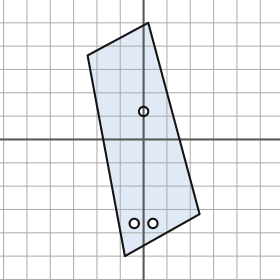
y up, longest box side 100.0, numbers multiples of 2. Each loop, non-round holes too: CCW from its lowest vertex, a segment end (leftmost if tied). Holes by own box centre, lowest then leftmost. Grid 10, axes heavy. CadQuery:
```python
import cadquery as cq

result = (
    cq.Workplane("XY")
    .moveTo(-8.0, -50.0)
    .lineTo(24.0, -32.0)
    .lineTo(2.0, 50.0)
    .lineTo(-24.0, 36.0)
    .close()
    .moveTo(-4.0, -36.0)
    .circle(2.0)
    .moveTo(4.0, -36.0)
    .circle(2.0)
    .moveTo(0.0, 12.0)
    .circle(2.0)
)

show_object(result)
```